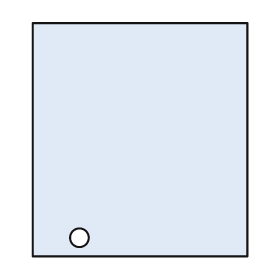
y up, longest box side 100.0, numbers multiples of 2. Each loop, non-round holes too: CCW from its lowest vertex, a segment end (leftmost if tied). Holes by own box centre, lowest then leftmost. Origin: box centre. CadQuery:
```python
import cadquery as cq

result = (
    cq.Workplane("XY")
    .moveTo(-46.0, -50.0)
    .lineTo(46.0, -50.0)
    .lineTo(46.0, 50.0)
    .lineTo(-46.0, 50.0)
    .close()
    .moveTo(-26.0, -42.0)
    .circle(4.0)
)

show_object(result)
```